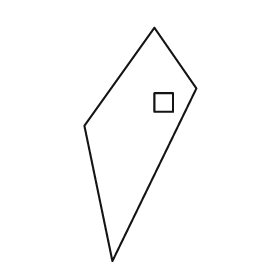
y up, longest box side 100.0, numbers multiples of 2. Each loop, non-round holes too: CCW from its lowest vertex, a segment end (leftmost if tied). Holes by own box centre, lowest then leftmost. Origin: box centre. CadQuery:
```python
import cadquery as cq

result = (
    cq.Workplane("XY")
    .moveTo(-12.0, -50.0)
    .lineTo(24.0, 24.0)
    .lineTo(6.0, 50.0)
    .lineTo(-24.0, 8.0)
    .close()
    .moveTo(6.0, 14.0)
    .lineTo(14.0, 14.0)
    .lineTo(14.0, 22.0)
    .lineTo(6.0, 22.0)
    .close()
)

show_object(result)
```